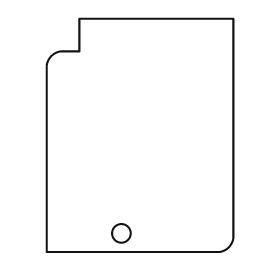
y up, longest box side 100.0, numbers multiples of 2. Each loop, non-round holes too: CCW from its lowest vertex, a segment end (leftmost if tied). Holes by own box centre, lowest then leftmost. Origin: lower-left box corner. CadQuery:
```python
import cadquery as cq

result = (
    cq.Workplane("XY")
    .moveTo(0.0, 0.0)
    .lineTo(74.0, 0.0)
    .threePointArc((78.0, 2.0), (80.0, 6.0))
    .lineTo(80.0, 100.0)
    .lineTo(14.0, 100.0)
    .lineTo(14.0, 86.0)
    .lineTo(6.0, 86.0)
    .threePointArc((2.0, 84.0), (0.0, 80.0))
    .close()
    .moveTo(32.0, 8.0)
    .circle(4.0)
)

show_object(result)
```